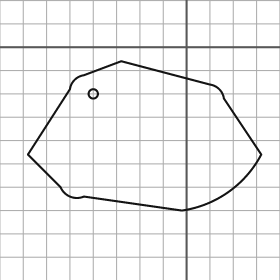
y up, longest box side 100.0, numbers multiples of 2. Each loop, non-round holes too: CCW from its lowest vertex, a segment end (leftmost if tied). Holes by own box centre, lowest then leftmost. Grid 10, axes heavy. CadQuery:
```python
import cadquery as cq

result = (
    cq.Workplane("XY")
    .moveTo(-2.0, -70.0)
    .threePointArc((18.0, -62.0), (32.0, -46.0))
    .lineTo(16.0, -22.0)
    .threePointArc((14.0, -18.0), (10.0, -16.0))
    .lineTo(-28.0, -6.0)
    .lineTo(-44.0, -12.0)
    .threePointArc((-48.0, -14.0), (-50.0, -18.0))
    .lineTo(-68.0, -46.0)
    .lineTo(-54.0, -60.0)
    .threePointArc((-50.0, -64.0), (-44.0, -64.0))
    .close()
    .moveTo(-40.0, -20.0)
    .circle(2.0)
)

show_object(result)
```